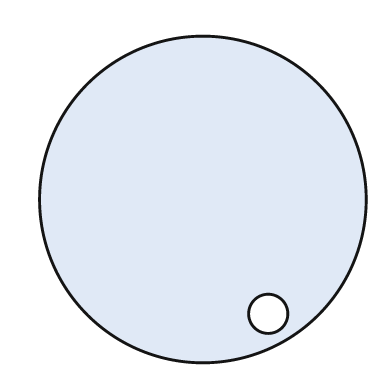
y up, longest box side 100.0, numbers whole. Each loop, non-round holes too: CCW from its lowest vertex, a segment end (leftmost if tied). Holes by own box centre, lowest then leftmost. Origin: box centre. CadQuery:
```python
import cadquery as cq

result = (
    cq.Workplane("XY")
    .moveTo(0.0, 0.0)
    .circle(50.0)
    .moveTo(20.0, -35.0)
    .circle(6.0)
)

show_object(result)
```